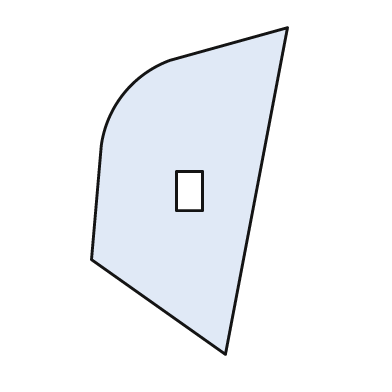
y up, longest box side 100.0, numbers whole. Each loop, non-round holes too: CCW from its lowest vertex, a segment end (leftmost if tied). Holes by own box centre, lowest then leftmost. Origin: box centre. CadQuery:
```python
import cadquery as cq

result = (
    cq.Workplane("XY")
    .moveTo(11.0, -50.0)
    .lineTo(30.0, 50.0)
    .lineTo(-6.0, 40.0)
    .threePointArc((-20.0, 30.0), (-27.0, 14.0))
    .lineTo(-30.0, -21.0)
    .close()
    .moveTo(-4.0, -6.0)
    .lineTo(4.0, -6.0)
    .lineTo(4.0, 6.0)
    .lineTo(-4.0, 6.0)
    .close()
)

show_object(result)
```